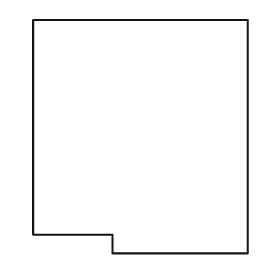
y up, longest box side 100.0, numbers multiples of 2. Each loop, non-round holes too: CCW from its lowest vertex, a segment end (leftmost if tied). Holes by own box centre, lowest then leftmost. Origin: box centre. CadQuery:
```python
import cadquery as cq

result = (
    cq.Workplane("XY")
    .moveTo(-12.0, -50.0)
    .lineTo(46.0, -50.0)
    .lineTo(46.0, 50.0)
    .lineTo(-46.0, 50.0)
    .lineTo(-46.0, -42.0)
    .lineTo(-12.0, -42.0)
    .close()
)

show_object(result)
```